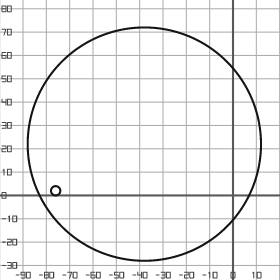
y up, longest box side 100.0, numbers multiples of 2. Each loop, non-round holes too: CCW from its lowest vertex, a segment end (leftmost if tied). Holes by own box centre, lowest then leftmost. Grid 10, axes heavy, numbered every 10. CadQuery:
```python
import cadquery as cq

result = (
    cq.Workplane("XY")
    .moveTo(-38.0, 22.0)
    .circle(50.0)
    .moveTo(-76.0, 2.0)
    .circle(2.0)
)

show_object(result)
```